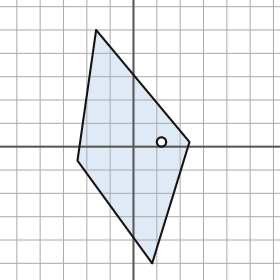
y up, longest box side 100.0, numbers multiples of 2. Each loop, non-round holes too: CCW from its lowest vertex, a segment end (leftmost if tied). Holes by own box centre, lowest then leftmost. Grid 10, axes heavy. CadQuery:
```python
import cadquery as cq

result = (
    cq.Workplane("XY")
    .moveTo(8.0, -50.0)
    .lineTo(24.0, 2.0)
    .lineTo(-16.0, 50.0)
    .lineTo(-24.0, -6.0)
    .close()
    .moveTo(12.0, 2.0)
    .circle(2.0)
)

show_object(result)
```